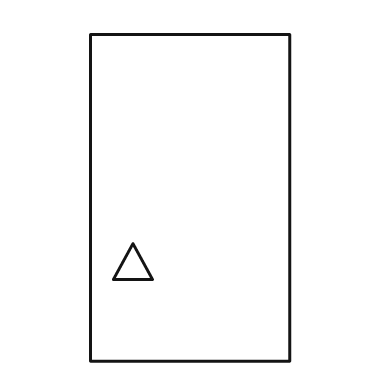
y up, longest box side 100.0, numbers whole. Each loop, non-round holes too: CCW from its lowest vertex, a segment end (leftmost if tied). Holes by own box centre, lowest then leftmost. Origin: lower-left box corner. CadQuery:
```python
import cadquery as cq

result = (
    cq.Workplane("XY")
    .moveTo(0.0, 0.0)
    .lineTo(61.0, 0.0)
    .lineTo(61.0, 100.0)
    .lineTo(0.0, 100.0)
    .close()
    .moveTo(7.0, 25.0)
    .lineTo(19.0, 25.0)
    .lineTo(13.0, 36.0)
    .close()
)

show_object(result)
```